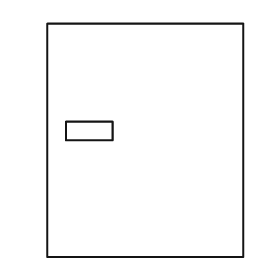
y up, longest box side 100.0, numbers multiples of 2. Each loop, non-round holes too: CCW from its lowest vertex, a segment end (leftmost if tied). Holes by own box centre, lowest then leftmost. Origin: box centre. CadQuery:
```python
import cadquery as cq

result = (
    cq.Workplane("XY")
    .moveTo(-42.0, -50.0)
    .lineTo(42.0, -50.0)
    .lineTo(42.0, 50.0)
    .lineTo(-42.0, 50.0)
    .close()
    .moveTo(-34.0, 0.0)
    .lineTo(-14.0, 0.0)
    .lineTo(-14.0, 8.0)
    .lineTo(-34.0, 8.0)
    .close()
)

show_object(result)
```